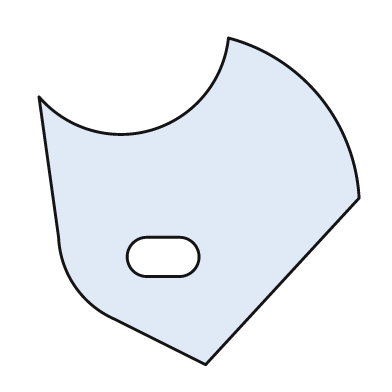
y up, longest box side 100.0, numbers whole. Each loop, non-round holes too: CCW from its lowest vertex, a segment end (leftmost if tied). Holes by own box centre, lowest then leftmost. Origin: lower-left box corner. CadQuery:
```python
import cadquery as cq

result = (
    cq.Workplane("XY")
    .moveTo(51.0, 0.0)
    .lineTo(98.0, 51.0)
    .threePointArc((86.0, 82.0), (58.0, 100.0))
    .threePointArc((35.0, 72.0), (0.0, 82.0))
    .lineTo(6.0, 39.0)
    .threePointArc((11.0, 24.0), (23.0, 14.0))
    .close()
    .moveTo(33.0, 27.0)
    .lineTo(43.0, 27.0)
    .threePointArc((49.0, 33.0), (43.0, 39.0))
    .lineTo(33.0, 39.0)
    .threePointArc((27.0, 33.0), (33.0, 27.0))
    .close()
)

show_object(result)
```